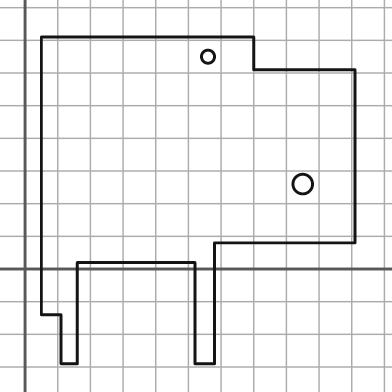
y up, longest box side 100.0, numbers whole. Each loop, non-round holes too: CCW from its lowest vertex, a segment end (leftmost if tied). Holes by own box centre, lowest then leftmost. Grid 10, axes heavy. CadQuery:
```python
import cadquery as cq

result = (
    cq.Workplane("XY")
    .moveTo(11.0, -29.0)
    .lineTo(16.0, -29.0)
    .lineTo(16.0, 2.0)
    .lineTo(52.0, 2.0)
    .lineTo(52.0, -29.0)
    .lineTo(58.0, -29.0)
    .lineTo(58.0, 8.0)
    .lineTo(101.0, 8.0)
    .lineTo(101.0, 61.0)
    .lineTo(70.0, 61.0)
    .lineTo(70.0, 71.0)
    .lineTo(5.0, 71.0)
    .lineTo(5.0, -14.0)
    .lineTo(11.0, -14.0)
    .close()
    .moveTo(85.0, 26.0)
    .circle(3.0)
    .moveTo(56.0, 65.0)
    .circle(2.0)
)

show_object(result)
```